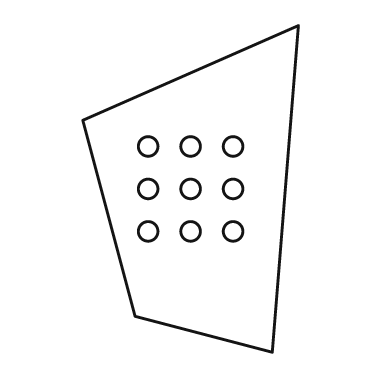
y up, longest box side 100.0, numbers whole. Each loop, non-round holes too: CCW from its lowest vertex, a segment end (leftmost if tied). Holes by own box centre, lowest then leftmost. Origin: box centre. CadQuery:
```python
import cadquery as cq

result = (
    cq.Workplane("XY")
    .moveTo(25.0, -50.0)
    .lineTo(33.0, 50.0)
    .lineTo(-33.0, 21.0)
    .lineTo(-17.0, -39.0)
    .close()
    .moveTo(-13.0, -13.0)
    .circle(3.0)
    .moveTo(0.0, -13.0)
    .circle(3.0)
    .moveTo(13.0, -13.0)
    .circle(3.0)
    .moveTo(-13.0, 0.0)
    .circle(3.0)
    .moveTo(0.0, 0.0)
    .circle(3.0)
    .moveTo(13.0, 0.0)
    .circle(3.0)
    .moveTo(-13.0, 13.0)
    .circle(3.0)
    .moveTo(0.0, 13.0)
    .circle(3.0)
    .moveTo(13.0, 13.0)
    .circle(3.0)
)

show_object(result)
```